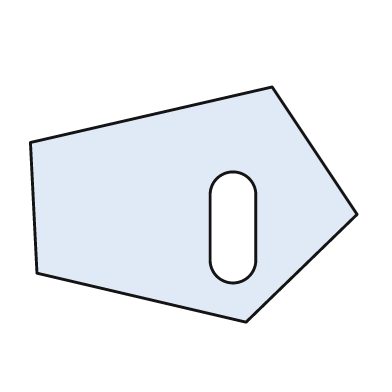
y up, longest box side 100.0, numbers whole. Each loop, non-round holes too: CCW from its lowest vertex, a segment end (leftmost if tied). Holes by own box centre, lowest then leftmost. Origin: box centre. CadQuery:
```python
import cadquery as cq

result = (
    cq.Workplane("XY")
    .moveTo(16.0, -36.0)
    .lineTo(50.0, -3.0)
    .lineTo(24.0, 36.0)
    .lineTo(-50.0, 19.0)
    .lineTo(-48.0, -21.0)
    .close()
    .moveTo(5.0, -17.0)
    .threePointArc((12.0, -24.0), (19.0, -17.0))
    .lineTo(19.0, 3.0)
    .threePointArc((12.0, 10.0), (5.0, 3.0))
    .close()
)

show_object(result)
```